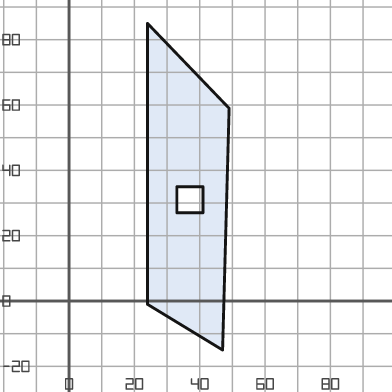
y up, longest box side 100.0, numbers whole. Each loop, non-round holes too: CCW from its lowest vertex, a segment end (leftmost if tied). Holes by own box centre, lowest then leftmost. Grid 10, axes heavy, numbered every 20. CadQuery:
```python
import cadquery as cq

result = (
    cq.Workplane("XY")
    .moveTo(47.0, -15.0)
    .lineTo(49.0, 59.0)
    .lineTo(24.0, 85.0)
    .lineTo(24.0, -1.0)
    .close()
    .moveTo(33.0, 27.0)
    .lineTo(41.0, 27.0)
    .lineTo(41.0, 35.0)
    .lineTo(33.0, 35.0)
    .close()
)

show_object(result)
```